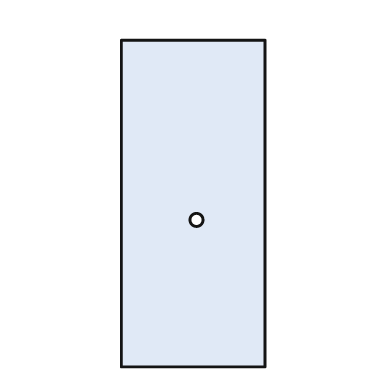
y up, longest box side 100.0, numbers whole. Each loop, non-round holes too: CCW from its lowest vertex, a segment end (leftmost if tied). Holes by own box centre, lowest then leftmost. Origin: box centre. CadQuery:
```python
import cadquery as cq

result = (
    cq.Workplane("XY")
    .moveTo(-22.0, -50.0)
    .lineTo(22.0, -50.0)
    .lineTo(22.0, 50.0)
    .lineTo(-22.0, 50.0)
    .close()
    .moveTo(1.0, -5.0)
    .circle(2.0)
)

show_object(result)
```